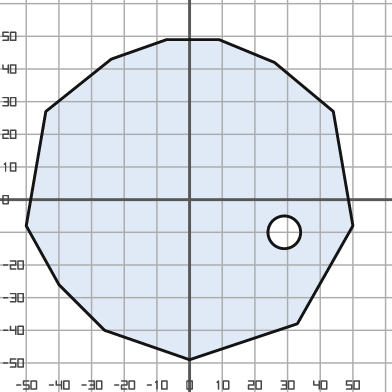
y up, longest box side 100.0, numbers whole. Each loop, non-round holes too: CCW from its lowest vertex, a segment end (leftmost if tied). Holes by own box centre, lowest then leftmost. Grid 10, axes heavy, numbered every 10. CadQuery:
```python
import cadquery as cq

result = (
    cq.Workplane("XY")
    .moveTo(0.0, -49.0)
    .lineTo(33.0, -38.0)
    .lineTo(50.0, -8.0)
    .lineTo(44.0, 27.0)
    .lineTo(26.0, 42.0)
    .lineTo(9.0, 49.0)
    .lineTo(-7.0, 49.0)
    .lineTo(-24.0, 43.0)
    .lineTo(-44.0, 27.0)
    .lineTo(-50.0, -8.0)
    .lineTo(-40.0, -26.0)
    .lineTo(-26.0, -40.0)
    .close()
    .moveTo(29.0, -10.0)
    .circle(5.0)
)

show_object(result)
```